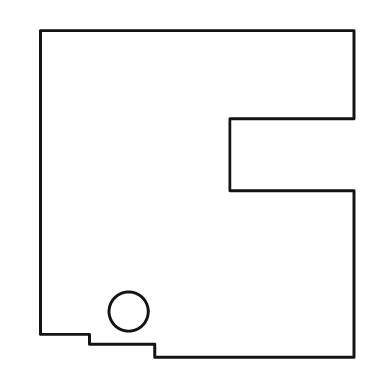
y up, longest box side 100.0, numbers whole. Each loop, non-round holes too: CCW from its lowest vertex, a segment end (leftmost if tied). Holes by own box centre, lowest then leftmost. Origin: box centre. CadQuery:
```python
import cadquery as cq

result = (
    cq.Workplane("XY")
    .moveTo(-13.0, -50.0)
    .lineTo(48.0, -50.0)
    .lineTo(48.0, 1.0)
    .lineTo(10.0, 1.0)
    .lineTo(10.0, 23.0)
    .lineTo(48.0, 23.0)
    .lineTo(48.0, 50.0)
    .lineTo(-48.0, 50.0)
    .lineTo(-48.0, -43.0)
    .lineTo(-33.0, -43.0)
    .lineTo(-33.0, -46.0)
    .lineTo(-13.0, -46.0)
    .close()
    .moveTo(-21.0, -36.0)
    .circle(6.0)
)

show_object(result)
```